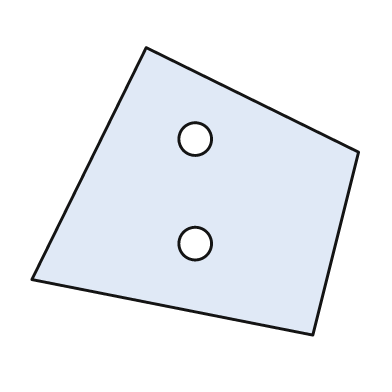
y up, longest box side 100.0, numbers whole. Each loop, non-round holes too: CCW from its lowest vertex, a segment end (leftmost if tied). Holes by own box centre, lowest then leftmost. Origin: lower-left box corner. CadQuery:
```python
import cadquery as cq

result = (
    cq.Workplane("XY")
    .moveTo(86.0, 0.0)
    .lineTo(100.0, 56.0)
    .lineTo(35.0, 88.0)
    .lineTo(0.0, 17.0)
    .close()
    .moveTo(50.0, 28.0)
    .circle(5.0)
    .moveTo(50.0, 60.0)
    .circle(5.0)
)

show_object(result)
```